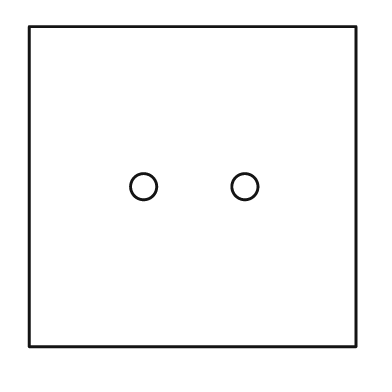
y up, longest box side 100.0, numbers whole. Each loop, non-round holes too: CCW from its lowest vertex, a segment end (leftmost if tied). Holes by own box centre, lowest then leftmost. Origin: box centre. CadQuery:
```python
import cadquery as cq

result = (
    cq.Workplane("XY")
    .moveTo(-50.0, -49.0)
    .lineTo(50.0, -49.0)
    .lineTo(50.0, 49.0)
    .lineTo(-50.0, 49.0)
    .close()
    .moveTo(-15.0, 0.0)
    .circle(4.0)
    .moveTo(16.0, 0.0)
    .circle(4.0)
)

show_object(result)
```